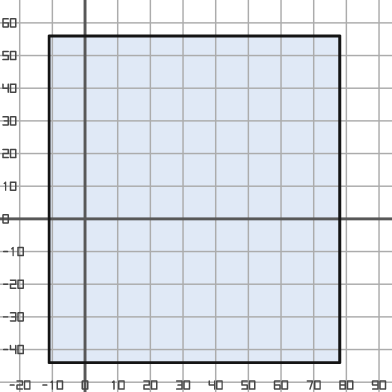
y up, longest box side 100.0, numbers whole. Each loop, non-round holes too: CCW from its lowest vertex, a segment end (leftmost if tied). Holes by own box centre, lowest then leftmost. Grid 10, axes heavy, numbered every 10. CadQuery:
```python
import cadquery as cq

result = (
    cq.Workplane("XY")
    .moveTo(-11.0, -44.0)
    .lineTo(78.0, -44.0)
    .lineTo(78.0, 56.0)
    .lineTo(-11.0, 56.0)
    .close()
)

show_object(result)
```